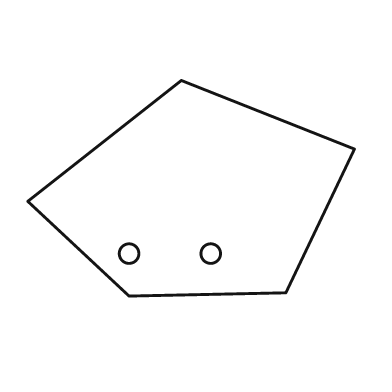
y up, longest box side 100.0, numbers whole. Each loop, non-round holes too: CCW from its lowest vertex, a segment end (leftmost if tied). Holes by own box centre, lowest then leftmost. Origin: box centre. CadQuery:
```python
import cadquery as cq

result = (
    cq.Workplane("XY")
    .moveTo(-19.0, -33.0)
    .lineTo(29.0, -32.0)
    .lineTo(50.0, 12.0)
    .lineTo(-3.0, 33.0)
    .lineTo(-50.0, -4.0)
    .close()
    .moveTo(-19.0, -20.0)
    .circle(3.0)
    .moveTo(6.0, -20.0)
    .circle(3.0)
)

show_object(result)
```